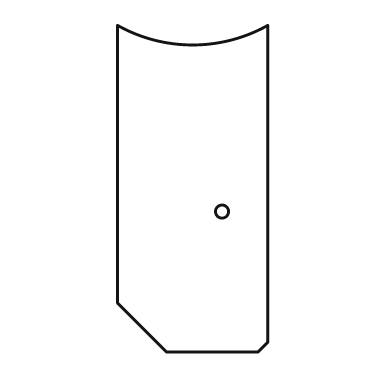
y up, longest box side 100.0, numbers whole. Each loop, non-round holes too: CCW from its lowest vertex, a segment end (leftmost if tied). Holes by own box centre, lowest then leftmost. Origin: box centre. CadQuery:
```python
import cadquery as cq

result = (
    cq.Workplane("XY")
    .moveTo(-8.0, -50.0)
    .lineTo(20.0, -50.0)
    .lineTo(23.0, -47.0)
    .lineTo(23.0, 50.0)
    .threePointArc((0.0, 44.0), (-23.0, 50.0))
    .lineTo(-23.0, -35.0)
    .close()
    .moveTo(9.0, -7.0)
    .circle(2.0)
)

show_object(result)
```